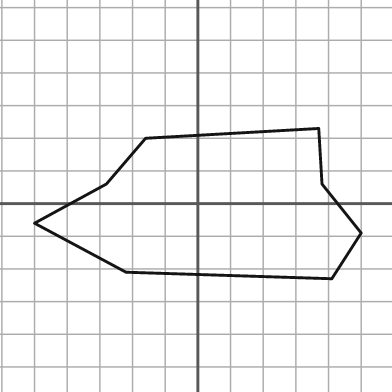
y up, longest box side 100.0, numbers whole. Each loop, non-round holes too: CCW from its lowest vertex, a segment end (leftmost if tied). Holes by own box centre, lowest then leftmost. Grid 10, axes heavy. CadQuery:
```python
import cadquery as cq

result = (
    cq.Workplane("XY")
    .moveTo(41.0, -23.0)
    .lineTo(50.0, -9.0)
    .lineTo(38.0, 6.0)
    .lineTo(37.0, 23.0)
    .lineTo(-16.0, 20.0)
    .lineTo(-28.0, 6.0)
    .lineTo(-50.0, -6.0)
    .lineTo(-22.0, -21.0)
    .close()
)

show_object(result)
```